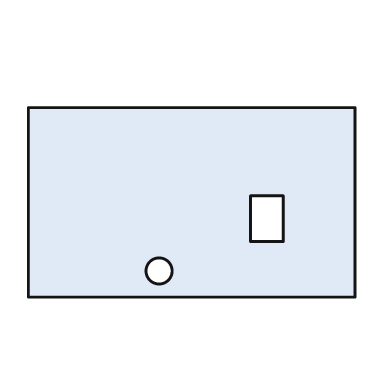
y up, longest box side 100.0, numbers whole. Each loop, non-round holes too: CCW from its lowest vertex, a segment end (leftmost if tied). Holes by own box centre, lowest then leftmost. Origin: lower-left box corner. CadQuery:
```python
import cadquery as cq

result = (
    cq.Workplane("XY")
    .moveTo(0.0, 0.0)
    .lineTo(100.0, 0.0)
    .lineTo(100.0, 58.0)
    .lineTo(0.0, 58.0)
    .close()
    .moveTo(40.0, 8.0)
    .circle(4.0)
    .moveTo(68.0, 17.0)
    .lineTo(78.0, 17.0)
    .lineTo(78.0, 31.0)
    .lineTo(68.0, 31.0)
    .close()
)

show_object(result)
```